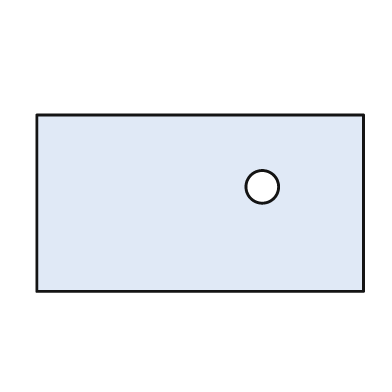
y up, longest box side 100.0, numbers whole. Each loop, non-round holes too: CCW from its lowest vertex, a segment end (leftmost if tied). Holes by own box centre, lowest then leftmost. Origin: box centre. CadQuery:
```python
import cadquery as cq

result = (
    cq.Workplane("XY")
    .moveTo(-50.0, -27.0)
    .lineTo(50.0, -27.0)
    .lineTo(50.0, 27.0)
    .lineTo(-50.0, 27.0)
    .close()
    .moveTo(19.0, 5.0)
    .circle(5.0)
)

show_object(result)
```